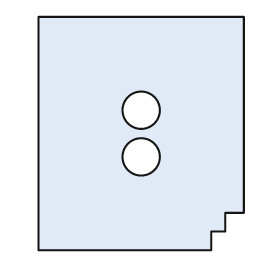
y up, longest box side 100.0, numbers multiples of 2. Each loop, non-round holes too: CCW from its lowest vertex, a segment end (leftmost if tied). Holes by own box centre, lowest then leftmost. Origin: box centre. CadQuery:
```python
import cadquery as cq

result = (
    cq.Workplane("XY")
    .moveTo(-44.0, -50.0)
    .lineTo(30.0, -50.0)
    .lineTo(30.0, -42.0)
    .lineTo(36.0, -42.0)
    .lineTo(36.0, -34.0)
    .lineTo(44.0, -34.0)
    .lineTo(44.0, 50.0)
    .lineTo(-44.0, 50.0)
    .close()
    .moveTo(0.0, -10.0)
    .circle(8.0)
    .moveTo(0.0, 10.0)
    .circle(8.0)
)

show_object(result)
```